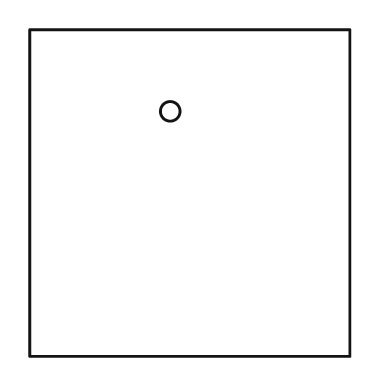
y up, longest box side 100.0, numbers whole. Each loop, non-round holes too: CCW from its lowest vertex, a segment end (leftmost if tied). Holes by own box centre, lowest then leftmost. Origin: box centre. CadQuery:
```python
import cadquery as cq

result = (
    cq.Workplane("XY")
    .moveTo(-49.0, -50.0)
    .lineTo(49.0, -50.0)
    .lineTo(49.0, 50.0)
    .lineTo(-49.0, 50.0)
    .close()
    .moveTo(-6.0, 25.0)
    .circle(3.0)
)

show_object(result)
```